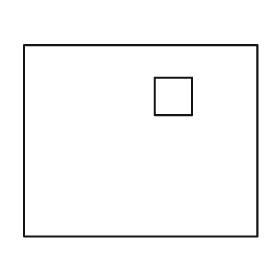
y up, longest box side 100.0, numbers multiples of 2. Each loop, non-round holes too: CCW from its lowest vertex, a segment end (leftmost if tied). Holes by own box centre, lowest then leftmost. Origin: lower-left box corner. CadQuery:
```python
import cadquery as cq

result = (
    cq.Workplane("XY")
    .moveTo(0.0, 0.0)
    .lineTo(100.0, 0.0)
    .lineTo(100.0, 82.0)
    .lineTo(0.0, 82.0)
    .close()
    .moveTo(56.0, 52.0)
    .lineTo(72.0, 52.0)
    .lineTo(72.0, 68.0)
    .lineTo(56.0, 68.0)
    .close()
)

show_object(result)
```